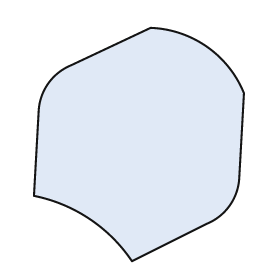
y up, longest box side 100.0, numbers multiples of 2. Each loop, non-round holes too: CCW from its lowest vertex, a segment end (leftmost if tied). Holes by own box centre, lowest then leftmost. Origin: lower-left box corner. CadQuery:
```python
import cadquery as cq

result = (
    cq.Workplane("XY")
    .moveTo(42.0, 0.0)
    .lineTo(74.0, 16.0)
    .threePointArc((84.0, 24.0), (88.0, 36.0))
    .lineTo(90.0, 72.0)
    .threePointArc((74.0, 92.0), (50.0, 100.0))
    .lineTo(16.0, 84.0)
    .threePointArc((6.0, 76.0), (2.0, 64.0))
    .lineTo(0.0, 28.0)
    .threePointArc((24.0, 18.0), (42.0, 0.0))
    .close()
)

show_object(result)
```